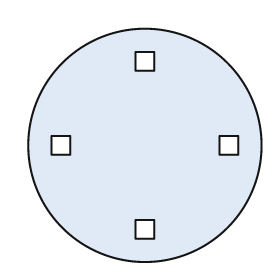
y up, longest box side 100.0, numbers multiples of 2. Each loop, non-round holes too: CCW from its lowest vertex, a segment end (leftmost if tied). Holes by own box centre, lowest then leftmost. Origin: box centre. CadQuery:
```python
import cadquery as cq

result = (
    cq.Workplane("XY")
    .moveTo(0.0, 0.0)
    .circle(50.0)
    .moveTo(-4.0, -40.0)
    .lineTo(4.0, -40.0)
    .lineTo(4.0, -32.0)
    .lineTo(-4.0, -32.0)
    .close()
    .moveTo(-40.0, -4.0)
    .lineTo(-32.0, -4.0)
    .lineTo(-32.0, 4.0)
    .lineTo(-40.0, 4.0)
    .close()
    .moveTo(32.0, -4.0)
    .lineTo(40.0, -4.0)
    .lineTo(40.0, 4.0)
    .lineTo(32.0, 4.0)
    .close()
    .moveTo(-4.0, 32.0)
    .lineTo(4.0, 32.0)
    .lineTo(4.0, 40.0)
    .lineTo(-4.0, 40.0)
    .close()
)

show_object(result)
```